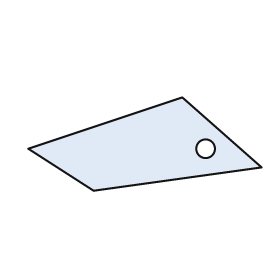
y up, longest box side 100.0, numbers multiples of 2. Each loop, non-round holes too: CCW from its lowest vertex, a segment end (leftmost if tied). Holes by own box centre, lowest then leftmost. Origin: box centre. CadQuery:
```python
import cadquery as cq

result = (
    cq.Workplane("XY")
    .moveTo(-22.0, -20.0)
    .lineTo(50.0, -10.0)
    .lineTo(16.0, 20.0)
    .lineTo(-50.0, -2.0)
    .close()
    .moveTo(26.0, -2.0)
    .circle(4.0)
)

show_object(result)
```